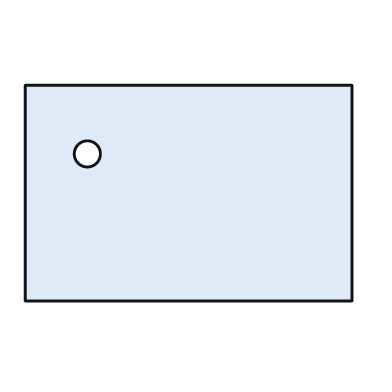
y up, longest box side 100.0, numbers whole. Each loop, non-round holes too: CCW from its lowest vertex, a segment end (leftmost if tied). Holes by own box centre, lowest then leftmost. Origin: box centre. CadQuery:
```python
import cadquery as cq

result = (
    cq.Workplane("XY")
    .moveTo(-50.0, -33.0)
    .lineTo(50.0, -33.0)
    .lineTo(50.0, 33.0)
    .lineTo(-50.0, 33.0)
    .close()
    .moveTo(-31.0, 12.0)
    .circle(4.0)
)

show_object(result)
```